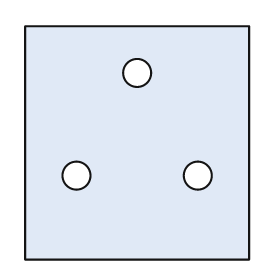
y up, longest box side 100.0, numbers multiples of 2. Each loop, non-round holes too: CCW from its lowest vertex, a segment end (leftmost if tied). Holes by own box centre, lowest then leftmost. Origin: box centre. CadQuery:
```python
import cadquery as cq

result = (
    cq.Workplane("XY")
    .moveTo(-48.0, -50.0)
    .lineTo(48.0, -50.0)
    .lineTo(48.0, 50.0)
    .lineTo(-48.0, 50.0)
    .close()
    .moveTo(-26.0, -14.0)
    .circle(6.0)
    .moveTo(26.0, -14.0)
    .circle(6.0)
    .moveTo(0.0, 30.0)
    .circle(6.0)
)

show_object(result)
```